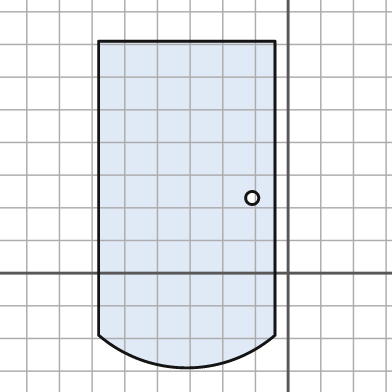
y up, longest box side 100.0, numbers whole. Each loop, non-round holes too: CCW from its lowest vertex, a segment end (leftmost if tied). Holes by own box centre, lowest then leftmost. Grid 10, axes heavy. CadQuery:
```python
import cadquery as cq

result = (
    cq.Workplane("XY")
    .moveTo(-58.0, -19.0)
    .threePointArc((-31.0, -29.0), (-4.0, -19.0))
    .lineTo(-4.0, 71.0)
    .lineTo(-58.0, 71.0)
    .close()
    .moveTo(-11.0, 23.0)
    .circle(2.0)
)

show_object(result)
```